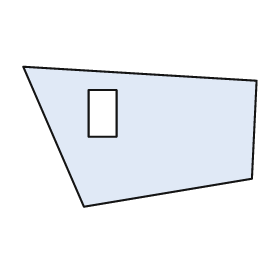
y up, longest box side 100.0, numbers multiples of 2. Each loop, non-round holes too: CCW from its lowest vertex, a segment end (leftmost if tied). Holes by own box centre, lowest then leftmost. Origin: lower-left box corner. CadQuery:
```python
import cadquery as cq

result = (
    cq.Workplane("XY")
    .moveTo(26.0, 0.0)
    .lineTo(98.0, 12.0)
    .lineTo(100.0, 54.0)
    .lineTo(0.0, 60.0)
    .close()
    .moveTo(28.0, 30.0)
    .lineTo(40.0, 30.0)
    .lineTo(40.0, 50.0)
    .lineTo(28.0, 50.0)
    .close()
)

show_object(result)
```